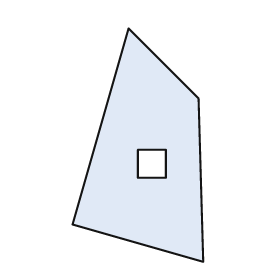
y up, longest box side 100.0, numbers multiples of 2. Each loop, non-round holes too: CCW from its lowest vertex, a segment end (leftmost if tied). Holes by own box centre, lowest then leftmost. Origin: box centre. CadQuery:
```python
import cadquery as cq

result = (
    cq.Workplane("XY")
    .moveTo(28.0, -50.0)
    .lineTo(26.0, 20.0)
    .lineTo(-4.0, 50.0)
    .lineTo(-28.0, -34.0)
    .close()
    .moveTo(0.0, -14.0)
    .lineTo(12.0, -14.0)
    .lineTo(12.0, -2.0)
    .lineTo(0.0, -2.0)
    .close()
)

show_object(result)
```